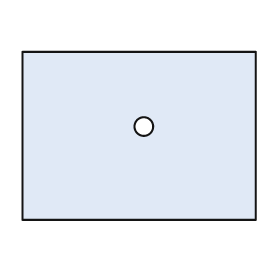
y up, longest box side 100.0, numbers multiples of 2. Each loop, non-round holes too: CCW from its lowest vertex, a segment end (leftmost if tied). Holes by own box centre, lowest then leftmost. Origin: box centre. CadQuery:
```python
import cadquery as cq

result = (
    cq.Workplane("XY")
    .moveTo(-50.0, -36.0)
    .lineTo(50.0, -36.0)
    .lineTo(50.0, 36.0)
    .lineTo(-50.0, 36.0)
    .close()
    .moveTo(2.0, 4.0)
    .circle(4.0)
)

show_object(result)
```